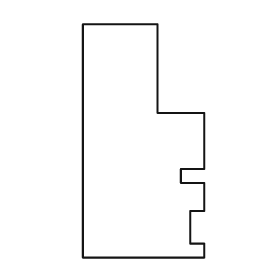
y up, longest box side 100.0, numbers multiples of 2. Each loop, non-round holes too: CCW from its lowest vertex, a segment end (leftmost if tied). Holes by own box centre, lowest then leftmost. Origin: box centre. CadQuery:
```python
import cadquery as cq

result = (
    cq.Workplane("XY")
    .moveTo(-26.0, -50.0)
    .lineTo(26.0, -50.0)
    .lineTo(26.0, -44.0)
    .lineTo(20.0, -44.0)
    .lineTo(20.0, -30.0)
    .lineTo(26.0, -30.0)
    .lineTo(26.0, -18.0)
    .lineTo(16.0, -18.0)
    .lineTo(16.0, -12.0)
    .lineTo(26.0, -12.0)
    .lineTo(26.0, 12.0)
    .lineTo(6.0, 12.0)
    .lineTo(6.0, 50.0)
    .lineTo(-26.0, 50.0)
    .close()
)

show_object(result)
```